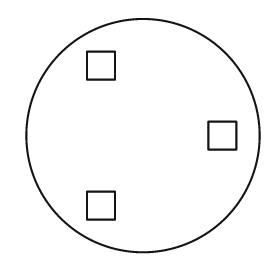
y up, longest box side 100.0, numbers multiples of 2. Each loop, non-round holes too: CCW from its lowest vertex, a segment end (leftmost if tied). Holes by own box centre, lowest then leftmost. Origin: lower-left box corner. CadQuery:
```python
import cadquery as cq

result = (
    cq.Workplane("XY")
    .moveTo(50.0, 50.0)
    .circle(50.0)
    .moveTo(26.0, 14.0)
    .lineTo(38.0, 14.0)
    .lineTo(38.0, 26.0)
    .lineTo(26.0, 26.0)
    .close()
    .moveTo(78.0, 44.0)
    .lineTo(90.0, 44.0)
    .lineTo(90.0, 56.0)
    .lineTo(78.0, 56.0)
    .close()
    .moveTo(26.0, 74.0)
    .lineTo(38.0, 74.0)
    .lineTo(38.0, 86.0)
    .lineTo(26.0, 86.0)
    .close()
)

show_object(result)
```